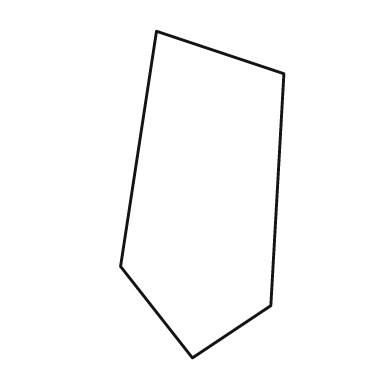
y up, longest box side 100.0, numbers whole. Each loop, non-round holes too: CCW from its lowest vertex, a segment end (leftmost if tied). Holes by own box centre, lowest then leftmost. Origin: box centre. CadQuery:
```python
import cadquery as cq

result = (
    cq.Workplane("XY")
    .moveTo(-3.0, -50.0)
    .lineTo(21.0, -34.0)
    .lineTo(25.0, 37.0)
    .lineTo(-14.0, 50.0)
    .lineTo(-25.0, -22.0)
    .close()
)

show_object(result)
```